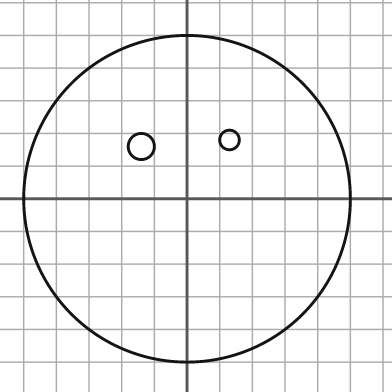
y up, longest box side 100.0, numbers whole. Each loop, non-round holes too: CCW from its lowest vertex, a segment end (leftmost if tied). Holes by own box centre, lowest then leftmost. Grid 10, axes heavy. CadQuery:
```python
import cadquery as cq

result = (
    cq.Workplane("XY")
    .moveTo(0.0, 0.0)
    .circle(50.0)
    .moveTo(-14.0, 16.0)
    .circle(4.0)
    .moveTo(13.0, 18.0)
    .circle(3.0)
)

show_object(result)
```